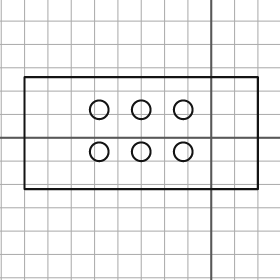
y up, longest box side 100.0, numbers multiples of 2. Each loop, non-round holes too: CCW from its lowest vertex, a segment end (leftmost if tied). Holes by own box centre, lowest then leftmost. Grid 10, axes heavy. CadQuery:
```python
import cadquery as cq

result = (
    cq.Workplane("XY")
    .moveTo(-80.0, -22.0)
    .lineTo(20.0, -22.0)
    .lineTo(20.0, 26.0)
    .lineTo(-80.0, 26.0)
    .close()
    .moveTo(-48.0, -6.0)
    .circle(4.0)
    .moveTo(-30.0, -6.0)
    .circle(4.0)
    .moveTo(-12.0, -6.0)
    .circle(4.0)
    .moveTo(-48.0, 12.0)
    .circle(4.0)
    .moveTo(-30.0, 12.0)
    .circle(4.0)
    .moveTo(-12.0, 12.0)
    .circle(4.0)
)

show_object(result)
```